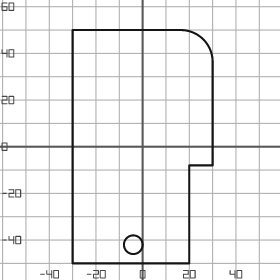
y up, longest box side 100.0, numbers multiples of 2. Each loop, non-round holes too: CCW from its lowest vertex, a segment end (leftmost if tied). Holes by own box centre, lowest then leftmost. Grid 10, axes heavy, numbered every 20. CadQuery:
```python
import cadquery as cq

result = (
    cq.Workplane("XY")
    .moveTo(-30.0, -50.0)
    .lineTo(20.0, -50.0)
    .lineTo(20.0, -8.0)
    .lineTo(30.0, -8.0)
    .lineTo(30.0, 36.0)
    .threePointArc((26.0, 46.0), (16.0, 50.0))
    .lineTo(-30.0, 50.0)
    .close()
    .moveTo(-4.0, -42.0)
    .circle(4.0)
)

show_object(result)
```